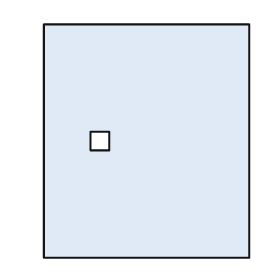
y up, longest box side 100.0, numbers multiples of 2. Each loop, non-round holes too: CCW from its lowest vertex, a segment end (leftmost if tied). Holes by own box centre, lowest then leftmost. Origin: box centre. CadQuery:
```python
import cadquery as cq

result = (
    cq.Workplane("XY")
    .moveTo(-44.0, -50.0)
    .lineTo(44.0, -50.0)
    .lineTo(44.0, 50.0)
    .lineTo(-44.0, 50.0)
    .close()
    .moveTo(-24.0, -4.0)
    .lineTo(-16.0, -4.0)
    .lineTo(-16.0, 4.0)
    .lineTo(-24.0, 4.0)
    .close()
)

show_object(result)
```